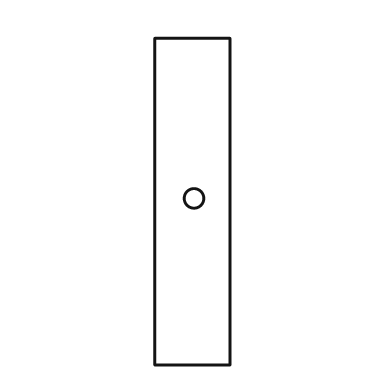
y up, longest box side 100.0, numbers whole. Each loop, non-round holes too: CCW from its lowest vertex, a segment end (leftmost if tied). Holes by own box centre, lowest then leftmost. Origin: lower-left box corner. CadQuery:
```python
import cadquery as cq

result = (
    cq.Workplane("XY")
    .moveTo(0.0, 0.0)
    .lineTo(23.0, 0.0)
    .lineTo(23.0, 100.0)
    .lineTo(0.0, 100.0)
    .close()
    .moveTo(12.0, 51.0)
    .circle(3.0)
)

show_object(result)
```